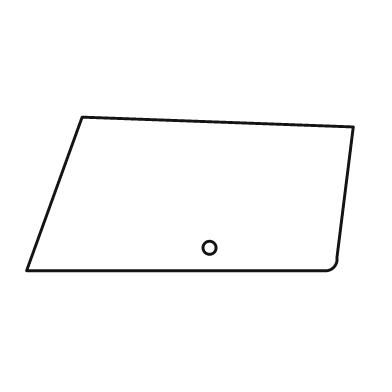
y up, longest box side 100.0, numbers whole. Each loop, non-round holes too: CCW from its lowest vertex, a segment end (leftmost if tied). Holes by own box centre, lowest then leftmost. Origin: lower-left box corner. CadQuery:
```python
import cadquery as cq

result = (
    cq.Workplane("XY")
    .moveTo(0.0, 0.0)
    .lineTo(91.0, 0.0)
    .threePointArc((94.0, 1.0), (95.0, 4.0))
    .lineTo(100.0, 44.0)
    .lineTo(17.0, 47.0)
    .close()
    .moveTo(56.0, 7.0)
    .circle(2.0)
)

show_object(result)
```